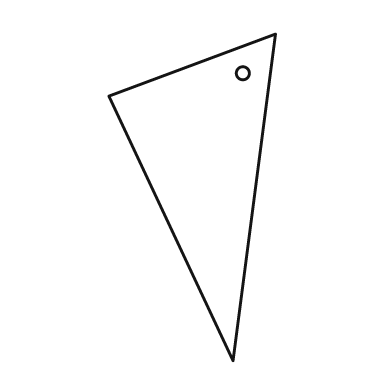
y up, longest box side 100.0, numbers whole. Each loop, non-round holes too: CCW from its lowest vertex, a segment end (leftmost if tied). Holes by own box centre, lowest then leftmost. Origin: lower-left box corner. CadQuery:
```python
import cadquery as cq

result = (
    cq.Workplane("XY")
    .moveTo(38.0, 0.0)
    .lineTo(51.0, 100.0)
    .lineTo(0.0, 81.0)
    .close()
    .moveTo(41.0, 88.0)
    .circle(2.0)
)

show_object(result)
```